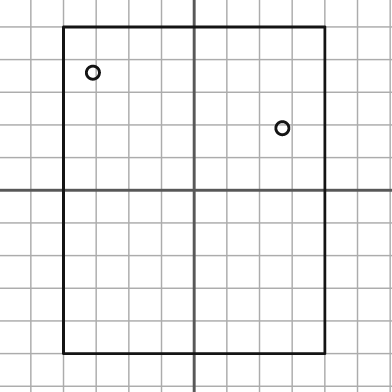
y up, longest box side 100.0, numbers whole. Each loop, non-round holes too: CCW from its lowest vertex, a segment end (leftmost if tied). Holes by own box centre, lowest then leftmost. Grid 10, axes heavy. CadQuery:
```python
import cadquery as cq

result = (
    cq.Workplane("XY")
    .moveTo(-40.0, -50.0)
    .lineTo(40.0, -50.0)
    .lineTo(40.0, 50.0)
    .lineTo(-40.0, 50.0)
    .close()
    .moveTo(27.0, 19.0)
    .circle(2.0)
    .moveTo(-31.0, 36.0)
    .circle(2.0)
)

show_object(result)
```